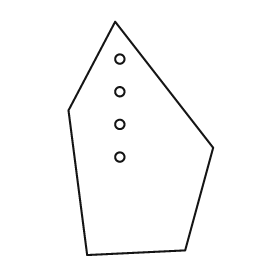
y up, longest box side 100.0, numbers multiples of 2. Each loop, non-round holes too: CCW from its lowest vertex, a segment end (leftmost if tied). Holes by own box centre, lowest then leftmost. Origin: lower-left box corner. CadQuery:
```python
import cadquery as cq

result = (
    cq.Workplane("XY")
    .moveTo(8.0, 0.0)
    .lineTo(50.0, 2.0)
    .lineTo(62.0, 46.0)
    .lineTo(20.0, 100.0)
    .lineTo(0.0, 62.0)
    .close()
    .moveTo(22.0, 42.0)
    .circle(2.0)
    .moveTo(22.0, 56.0)
    .circle(2.0)
    .moveTo(22.0, 70.0)
    .circle(2.0)
    .moveTo(22.0, 84.0)
    .circle(2.0)
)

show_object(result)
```